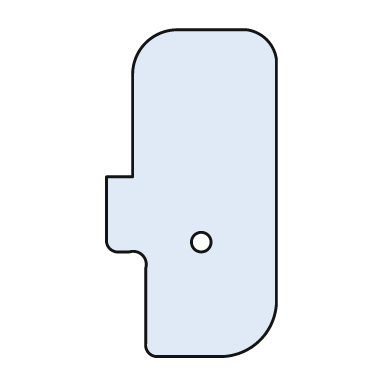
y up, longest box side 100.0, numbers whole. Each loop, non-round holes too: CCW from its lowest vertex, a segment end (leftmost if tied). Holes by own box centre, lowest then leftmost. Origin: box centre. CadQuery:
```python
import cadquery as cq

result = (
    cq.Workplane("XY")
    .moveTo(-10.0, -50.0)
    .lineTo(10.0, -50.0)
    .threePointArc((21.0, -45.0), (26.0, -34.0))
    .lineTo(26.0, 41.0)
    .threePointArc((23.0, 47.0), (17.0, 50.0))
    .lineTo(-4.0, 50.0)
    .threePointArc((-14.0, 46.0), (-18.0, 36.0))
    .lineTo(-18.0, 5.0)
    .lineTo(-26.0, 5.0)
    .lineTo(-26.0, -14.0)
    .threePointArc((-25.0, -17.0), (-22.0, -18.0))
    .lineTo(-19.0, -18.0)
    .threePointArc((-15.0, -19.0), (-14.0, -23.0))
    .lineTo(-14.0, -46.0)
    .threePointArc((-13.0, -49.0), (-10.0, -50.0))
    .close()
    .moveTo(3.0, -15.0)
    .circle(3.0)
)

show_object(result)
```